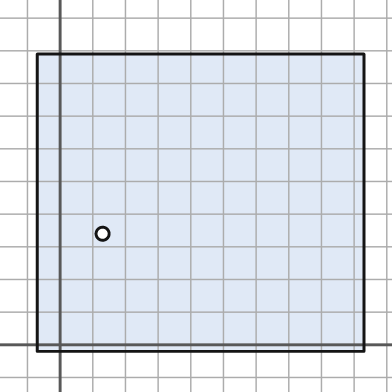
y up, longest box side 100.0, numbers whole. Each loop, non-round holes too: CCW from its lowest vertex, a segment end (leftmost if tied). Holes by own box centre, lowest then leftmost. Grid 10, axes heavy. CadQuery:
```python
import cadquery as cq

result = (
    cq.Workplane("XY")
    .moveTo(-7.0, -2.0)
    .lineTo(93.0, -2.0)
    .lineTo(93.0, 89.0)
    .lineTo(-7.0, 89.0)
    .close()
    .moveTo(13.0, 34.0)
    .circle(2.0)
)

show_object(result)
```